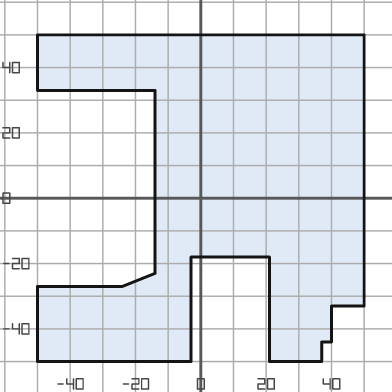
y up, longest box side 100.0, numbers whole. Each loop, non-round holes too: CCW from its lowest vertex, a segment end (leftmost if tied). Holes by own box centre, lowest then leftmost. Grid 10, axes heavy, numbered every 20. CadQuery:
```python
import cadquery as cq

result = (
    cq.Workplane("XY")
    .moveTo(-50.0, -50.0)
    .lineTo(-3.0, -50.0)
    .lineTo(-3.0, -18.0)
    .lineTo(21.0, -18.0)
    .lineTo(21.0, -50.0)
    .lineTo(37.0, -50.0)
    .lineTo(37.0, -44.0)
    .lineTo(40.0, -44.0)
    .lineTo(40.0, -33.0)
    .lineTo(50.0, -33.0)
    .lineTo(50.0, 50.0)
    .lineTo(-50.0, 50.0)
    .lineTo(-50.0, 33.0)
    .lineTo(-14.0, 33.0)
    .lineTo(-14.0, -23.0)
    .lineTo(-24.0, -27.0)
    .lineTo(-50.0, -27.0)
    .close()
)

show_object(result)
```